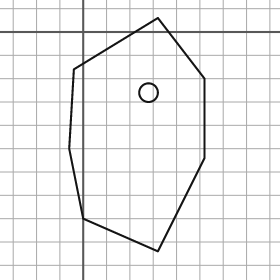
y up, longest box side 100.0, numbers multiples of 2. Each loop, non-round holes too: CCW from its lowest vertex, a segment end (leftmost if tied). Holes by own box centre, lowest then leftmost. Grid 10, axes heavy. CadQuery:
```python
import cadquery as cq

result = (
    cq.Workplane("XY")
    .moveTo(32.0, -94.0)
    .lineTo(52.0, -54.0)
    .lineTo(52.0, -20.0)
    .lineTo(32.0, 6.0)
    .lineTo(-4.0, -16.0)
    .lineTo(-6.0, -50.0)
    .lineTo(0.0, -80.0)
    .close()
    .moveTo(28.0, -26.0)
    .circle(4.0)
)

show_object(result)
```